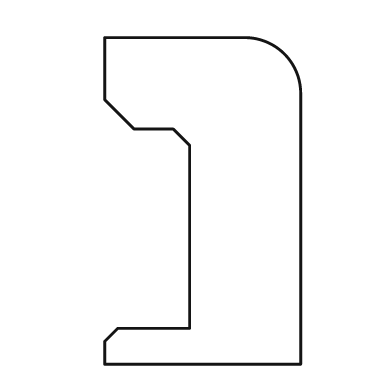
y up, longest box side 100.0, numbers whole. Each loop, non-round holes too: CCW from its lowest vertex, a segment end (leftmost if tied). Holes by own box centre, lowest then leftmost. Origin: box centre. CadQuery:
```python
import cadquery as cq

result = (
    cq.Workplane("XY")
    .moveTo(-30.0, -50.0)
    .lineTo(30.0, -50.0)
    .lineTo(30.0, 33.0)
    .threePointArc((25.0, 45.0), (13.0, 50.0))
    .lineTo(-30.0, 50.0)
    .lineTo(-30.0, 31.0)
    .lineTo(-21.0, 22.0)
    .lineTo(-9.0, 22.0)
    .lineTo(-4.0, 17.0)
    .lineTo(-4.0, -39.0)
    .lineTo(-26.0, -39.0)
    .lineTo(-30.0, -43.0)
    .close()
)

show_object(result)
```